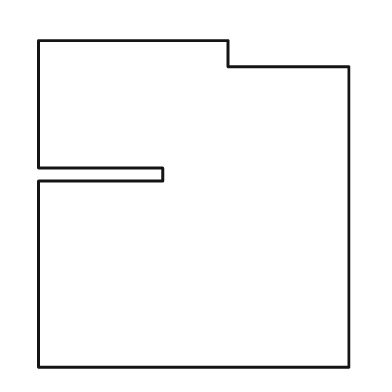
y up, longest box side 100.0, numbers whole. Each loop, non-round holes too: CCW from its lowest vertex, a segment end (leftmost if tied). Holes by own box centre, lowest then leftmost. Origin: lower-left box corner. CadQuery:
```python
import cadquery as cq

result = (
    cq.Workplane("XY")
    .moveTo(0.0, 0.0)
    .lineTo(95.0, 0.0)
    .lineTo(95.0, 92.0)
    .lineTo(58.0, 92.0)
    .lineTo(58.0, 100.0)
    .lineTo(0.0, 100.0)
    .lineTo(0.0, 61.0)
    .lineTo(38.0, 61.0)
    .lineTo(38.0, 57.0)
    .lineTo(0.0, 57.0)
    .close()
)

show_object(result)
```